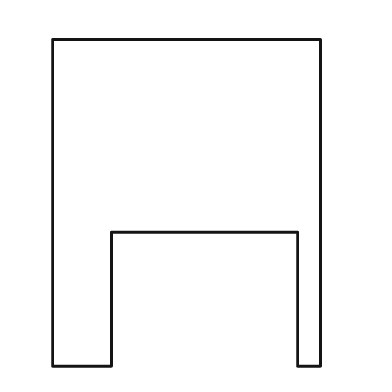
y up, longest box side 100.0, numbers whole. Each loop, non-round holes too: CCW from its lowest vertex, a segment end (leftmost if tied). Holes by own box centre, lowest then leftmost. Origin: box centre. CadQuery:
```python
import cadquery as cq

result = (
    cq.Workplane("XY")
    .moveTo(-41.0, -50.0)
    .lineTo(-23.0, -50.0)
    .lineTo(-23.0, -9.0)
    .lineTo(34.0, -9.0)
    .lineTo(34.0, -50.0)
    .lineTo(41.0, -50.0)
    .lineTo(41.0, 50.0)
    .lineTo(-41.0, 50.0)
    .close()
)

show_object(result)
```